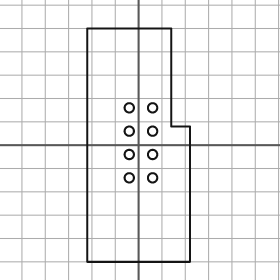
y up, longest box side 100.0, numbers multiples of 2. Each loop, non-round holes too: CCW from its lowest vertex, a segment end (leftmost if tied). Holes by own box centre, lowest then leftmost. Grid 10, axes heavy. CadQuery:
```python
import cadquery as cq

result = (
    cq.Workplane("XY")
    .moveTo(-22.0, -50.0)
    .lineTo(22.0, -50.0)
    .lineTo(22.0, 8.0)
    .lineTo(14.0, 8.0)
    .lineTo(14.0, 50.0)
    .lineTo(-22.0, 50.0)
    .close()
    .moveTo(-4.0, -14.0)
    .circle(2.0)
    .moveTo(6.0, -14.0)
    .circle(2.0)
    .moveTo(-4.0, -4.0)
    .circle(2.0)
    .moveTo(6.0, -4.0)
    .circle(2.0)
    .moveTo(-4.0, 6.0)
    .circle(2.0)
    .moveTo(6.0, 6.0)
    .circle(2.0)
    .moveTo(-4.0, 16.0)
    .circle(2.0)
    .moveTo(6.0, 16.0)
    .circle(2.0)
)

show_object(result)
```